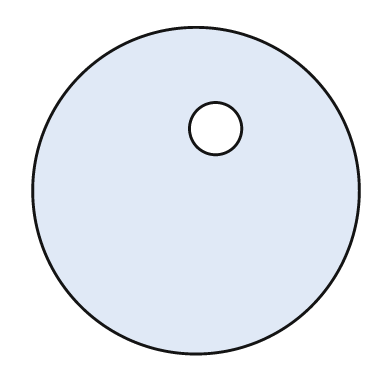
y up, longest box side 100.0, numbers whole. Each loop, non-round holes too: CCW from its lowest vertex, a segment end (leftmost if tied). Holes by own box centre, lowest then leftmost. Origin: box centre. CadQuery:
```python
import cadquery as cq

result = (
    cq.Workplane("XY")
    .moveTo(0.0, 0.0)
    .circle(50.0)
    .moveTo(6.0, 19.0)
    .circle(8.0)
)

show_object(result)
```